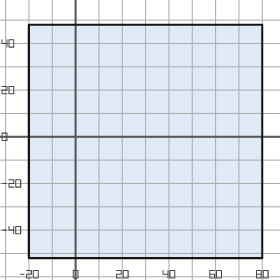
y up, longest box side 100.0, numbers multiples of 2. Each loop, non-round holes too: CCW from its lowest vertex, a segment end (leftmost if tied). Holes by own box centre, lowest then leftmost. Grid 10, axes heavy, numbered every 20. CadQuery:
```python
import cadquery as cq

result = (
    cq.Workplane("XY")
    .moveTo(-20.0, -52.0)
    .lineTo(80.0, -52.0)
    .lineTo(80.0, 48.0)
    .lineTo(-20.0, 48.0)
    .close()
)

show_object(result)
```